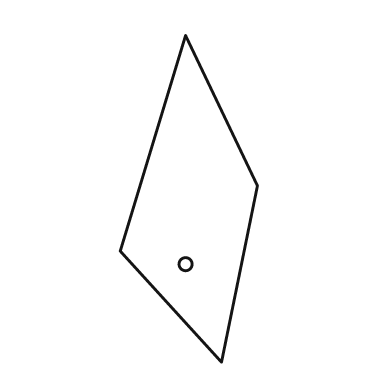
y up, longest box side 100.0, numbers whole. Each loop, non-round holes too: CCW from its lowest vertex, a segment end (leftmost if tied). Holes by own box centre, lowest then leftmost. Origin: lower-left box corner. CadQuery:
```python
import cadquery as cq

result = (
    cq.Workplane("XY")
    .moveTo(31.0, 0.0)
    .lineTo(42.0, 54.0)
    .lineTo(20.0, 100.0)
    .lineTo(0.0, 34.0)
    .close()
    .moveTo(20.0, 30.0)
    .circle(2.0)
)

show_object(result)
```